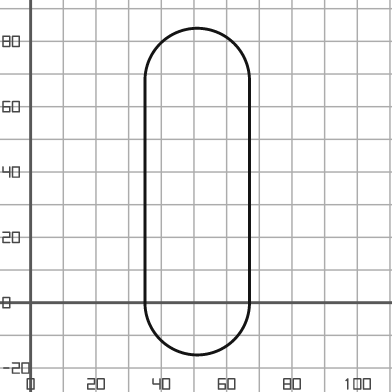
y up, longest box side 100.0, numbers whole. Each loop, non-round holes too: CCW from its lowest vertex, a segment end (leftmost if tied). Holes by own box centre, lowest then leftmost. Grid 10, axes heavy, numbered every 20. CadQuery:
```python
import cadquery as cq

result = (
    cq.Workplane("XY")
    .moveTo(35.0, 0.0)
    .threePointArc((51.0, -16.0), (67.0, 0.0))
    .lineTo(67.0, 68.0)
    .threePointArc((51.0, 84.0), (35.0, 68.0))
    .close()
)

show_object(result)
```